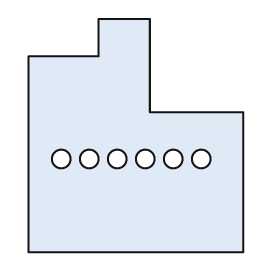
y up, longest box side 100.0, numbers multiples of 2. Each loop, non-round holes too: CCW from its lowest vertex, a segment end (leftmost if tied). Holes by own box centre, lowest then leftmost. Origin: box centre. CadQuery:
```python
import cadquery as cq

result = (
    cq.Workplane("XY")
    .moveTo(-46.0, -50.0)
    .lineTo(46.0, -50.0)
    .lineTo(46.0, 10.0)
    .lineTo(6.0, 10.0)
    .lineTo(6.0, 50.0)
    .lineTo(-16.0, 50.0)
    .lineTo(-16.0, 34.0)
    .lineTo(-46.0, 34.0)
    .close()
    .moveTo(-32.0, -10.0)
    .circle(4.0)
    .moveTo(-20.0, -10.0)
    .circle(4.0)
    .moveTo(-8.0, -10.0)
    .circle(4.0)
    .moveTo(4.0, -10.0)
    .circle(4.0)
    .moveTo(16.0, -10.0)
    .circle(4.0)
    .moveTo(28.0, -10.0)
    .circle(4.0)
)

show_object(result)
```